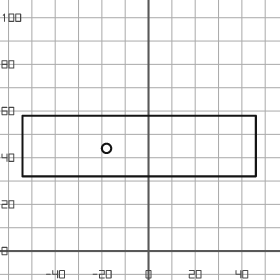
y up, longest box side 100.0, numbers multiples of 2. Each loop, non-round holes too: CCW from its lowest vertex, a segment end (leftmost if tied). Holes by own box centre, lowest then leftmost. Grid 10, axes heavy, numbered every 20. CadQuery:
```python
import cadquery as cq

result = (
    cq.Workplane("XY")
    .moveTo(-54.0, 32.0)
    .lineTo(46.0, 32.0)
    .lineTo(46.0, 58.0)
    .lineTo(-54.0, 58.0)
    .close()
    .moveTo(-18.0, 44.0)
    .circle(2.0)
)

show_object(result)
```